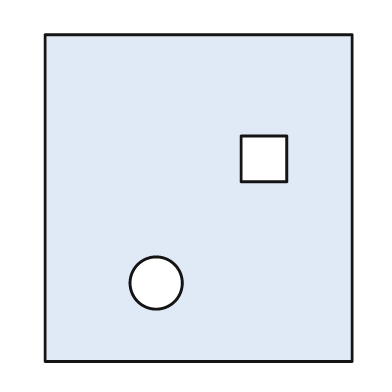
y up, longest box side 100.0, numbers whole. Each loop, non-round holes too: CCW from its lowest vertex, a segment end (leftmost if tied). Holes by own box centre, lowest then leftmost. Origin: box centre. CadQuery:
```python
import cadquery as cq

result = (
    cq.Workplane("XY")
    .moveTo(-47.0, -50.0)
    .lineTo(47.0, -50.0)
    .lineTo(47.0, 50.0)
    .lineTo(-47.0, 50.0)
    .close()
    .moveTo(-13.0, -26.0)
    .circle(8.0)
    .moveTo(13.0, 5.0)
    .lineTo(27.0, 5.0)
    .lineTo(27.0, 19.0)
    .lineTo(13.0, 19.0)
    .close()
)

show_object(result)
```